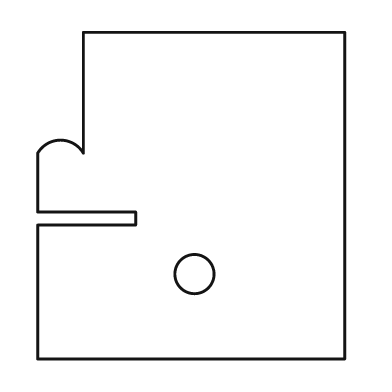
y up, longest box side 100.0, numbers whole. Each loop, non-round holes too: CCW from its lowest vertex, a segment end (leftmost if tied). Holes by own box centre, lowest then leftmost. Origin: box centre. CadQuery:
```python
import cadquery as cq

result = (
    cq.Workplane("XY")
    .moveTo(-47.0, -50.0)
    .lineTo(47.0, -50.0)
    .lineTo(47.0, 50.0)
    .lineTo(-33.0, 50.0)
    .lineTo(-33.0, 13.0)
    .threePointArc((-40.0, 17.0), (-47.0, 13.0))
    .lineTo(-47.0, -5.0)
    .lineTo(-17.0, -5.0)
    .lineTo(-17.0, -9.0)
    .lineTo(-47.0, -9.0)
    .close()
    .moveTo(1.0, -24.0)
    .circle(6.0)
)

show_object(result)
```